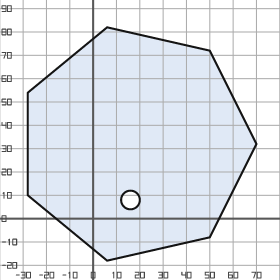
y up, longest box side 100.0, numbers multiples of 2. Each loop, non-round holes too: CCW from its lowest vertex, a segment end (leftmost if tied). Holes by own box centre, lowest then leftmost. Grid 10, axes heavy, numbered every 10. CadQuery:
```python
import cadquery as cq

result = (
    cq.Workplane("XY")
    .moveTo(6.0, -18.0)
    .lineTo(50.0, -8.0)
    .lineTo(70.0, 32.0)
    .lineTo(50.0, 72.0)
    .lineTo(6.0, 82.0)
    .lineTo(-28.0, 54.0)
    .lineTo(-28.0, 10.0)
    .close()
    .moveTo(16.0, 8.0)
    .circle(4.0)
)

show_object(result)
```